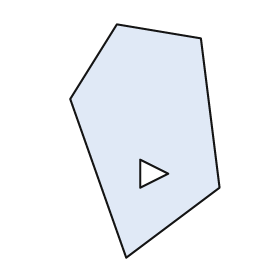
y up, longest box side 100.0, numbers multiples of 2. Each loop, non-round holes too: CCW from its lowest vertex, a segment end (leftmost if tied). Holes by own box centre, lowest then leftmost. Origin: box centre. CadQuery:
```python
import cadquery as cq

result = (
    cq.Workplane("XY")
    .moveTo(-8.0, -50.0)
    .lineTo(32.0, -20.0)
    .lineTo(24.0, 44.0)
    .lineTo(-12.0, 50.0)
    .lineTo(-32.0, 18.0)
    .close()
    .moveTo(-2.0, -20.0)
    .lineTo(10.0, -14.0)
    .lineTo(-2.0, -8.0)
    .close()
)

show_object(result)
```